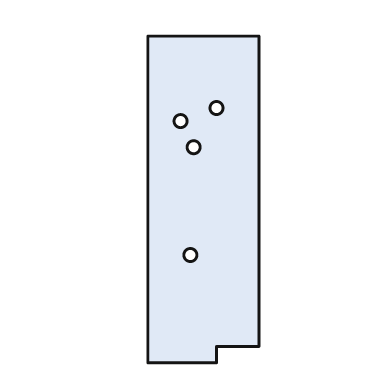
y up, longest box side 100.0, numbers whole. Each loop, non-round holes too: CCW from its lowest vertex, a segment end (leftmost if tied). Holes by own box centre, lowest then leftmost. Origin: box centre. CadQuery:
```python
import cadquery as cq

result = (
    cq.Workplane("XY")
    .moveTo(-17.0, -50.0)
    .lineTo(4.0, -50.0)
    .lineTo(4.0, -45.0)
    .lineTo(17.0, -45.0)
    .lineTo(17.0, 50.0)
    .lineTo(-17.0, 50.0)
    .close()
    .moveTo(-4.0, -17.0)
    .circle(2.0)
    .moveTo(-3.0, 16.0)
    .circle(2.0)
    .moveTo(-7.0, 24.0)
    .circle(2.0)
    .moveTo(4.0, 28.0)
    .circle(2.0)
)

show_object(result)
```